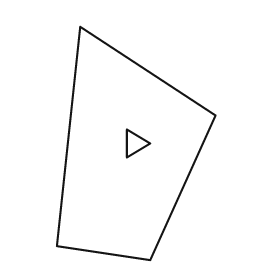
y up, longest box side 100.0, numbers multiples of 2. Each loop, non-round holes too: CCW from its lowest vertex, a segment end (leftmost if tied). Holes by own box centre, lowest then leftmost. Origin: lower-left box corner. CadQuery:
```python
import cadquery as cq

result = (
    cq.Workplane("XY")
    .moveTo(40.0, 0.0)
    .lineTo(68.0, 62.0)
    .lineTo(10.0, 100.0)
    .lineTo(0.0, 6.0)
    .close()
    .moveTo(30.0, 44.0)
    .lineTo(40.0, 50.0)
    .lineTo(30.0, 56.0)
    .close()
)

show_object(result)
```